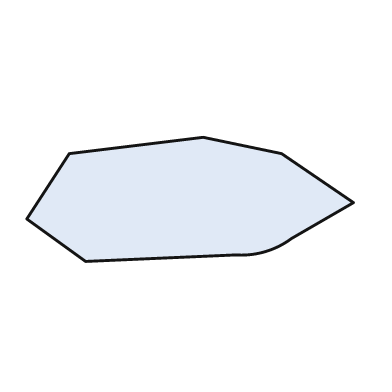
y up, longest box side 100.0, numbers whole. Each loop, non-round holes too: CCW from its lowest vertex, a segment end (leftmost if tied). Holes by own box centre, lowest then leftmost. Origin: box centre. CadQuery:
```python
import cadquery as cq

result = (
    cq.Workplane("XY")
    .moveTo(-32.0, -19.0)
    .lineTo(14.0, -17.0)
    .threePointArc((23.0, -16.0), (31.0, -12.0))
    .lineTo(50.0, -1.0)
    .lineTo(28.0, 14.0)
    .lineTo(4.0, 19.0)
    .lineTo(-37.0, 14.0)
    .lineTo(-50.0, -6.0)
    .close()
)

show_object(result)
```